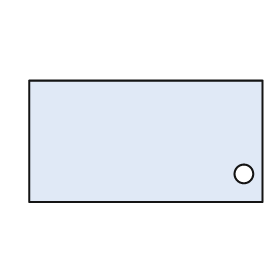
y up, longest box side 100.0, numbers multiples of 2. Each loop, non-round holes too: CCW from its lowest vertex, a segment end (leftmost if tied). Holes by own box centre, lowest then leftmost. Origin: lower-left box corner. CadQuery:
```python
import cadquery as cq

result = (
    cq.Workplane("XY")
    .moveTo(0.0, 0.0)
    .lineTo(100.0, 0.0)
    .lineTo(100.0, 52.0)
    .lineTo(0.0, 52.0)
    .close()
    .moveTo(92.0, 12.0)
    .circle(4.0)
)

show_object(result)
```